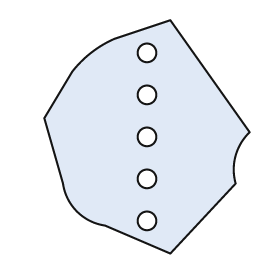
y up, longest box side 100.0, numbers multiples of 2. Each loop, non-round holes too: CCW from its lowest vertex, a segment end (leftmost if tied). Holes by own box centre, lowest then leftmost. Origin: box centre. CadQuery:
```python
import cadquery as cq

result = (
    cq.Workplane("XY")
    .moveTo(10.0, -50.0)
    .lineTo(38.0, -20.0)
    .threePointArc((38.0, -8.0), (44.0, 2.0))
    .lineTo(10.0, 50.0)
    .lineTo(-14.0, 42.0)
    .threePointArc((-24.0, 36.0), (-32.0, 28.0))
    .lineTo(-44.0, 8.0)
    .lineTo(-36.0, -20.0)
    .threePointArc((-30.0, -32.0), (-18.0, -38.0))
    .close()
    .moveTo(0.0, -36.0)
    .circle(4.0)
    .moveTo(0.0, -18.0)
    .circle(4.0)
    .moveTo(0.0, 0.0)
    .circle(4.0)
    .moveTo(0.0, 18.0)
    .circle(4.0)
    .moveTo(0.0, 36.0)
    .circle(4.0)
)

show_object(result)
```